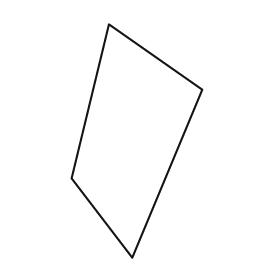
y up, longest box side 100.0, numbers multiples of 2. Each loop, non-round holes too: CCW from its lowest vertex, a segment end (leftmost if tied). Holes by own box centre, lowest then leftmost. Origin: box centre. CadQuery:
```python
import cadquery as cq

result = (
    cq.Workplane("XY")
    .moveTo(-2.0, -50.0)
    .lineTo(28.0, 22.0)
    .lineTo(-12.0, 50.0)
    .lineTo(-28.0, -16.0)
    .close()
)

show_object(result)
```